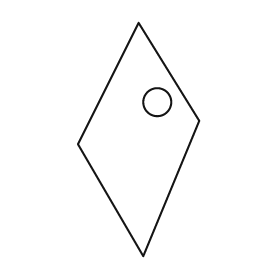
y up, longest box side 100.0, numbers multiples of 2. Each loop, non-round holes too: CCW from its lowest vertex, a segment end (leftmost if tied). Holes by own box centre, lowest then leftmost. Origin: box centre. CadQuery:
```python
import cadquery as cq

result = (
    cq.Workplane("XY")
    .moveTo(2.0, -50.0)
    .lineTo(26.0, 8.0)
    .lineTo(0.0, 50.0)
    .lineTo(-26.0, -2.0)
    .close()
    .moveTo(8.0, 16.0)
    .circle(6.0)
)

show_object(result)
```